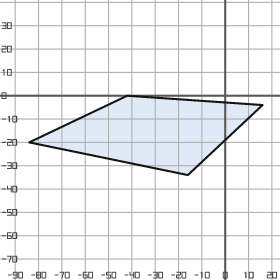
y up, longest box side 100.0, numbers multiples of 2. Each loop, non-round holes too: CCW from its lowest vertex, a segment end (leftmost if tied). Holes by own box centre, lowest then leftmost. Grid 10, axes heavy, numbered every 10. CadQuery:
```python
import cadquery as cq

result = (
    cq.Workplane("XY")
    .moveTo(-16.0, -34.0)
    .lineTo(16.0, -4.0)
    .lineTo(-42.0, 0.0)
    .lineTo(-84.0, -20.0)
    .close()
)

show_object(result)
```